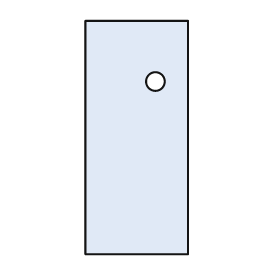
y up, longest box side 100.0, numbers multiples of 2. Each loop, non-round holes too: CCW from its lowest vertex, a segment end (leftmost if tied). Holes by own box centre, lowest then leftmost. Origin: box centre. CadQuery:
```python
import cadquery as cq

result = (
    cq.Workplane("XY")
    .moveTo(-22.0, -50.0)
    .lineTo(22.0, -50.0)
    .lineTo(22.0, 50.0)
    .lineTo(-22.0, 50.0)
    .close()
    .moveTo(8.0, 24.0)
    .circle(4.0)
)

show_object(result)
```